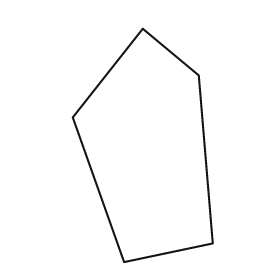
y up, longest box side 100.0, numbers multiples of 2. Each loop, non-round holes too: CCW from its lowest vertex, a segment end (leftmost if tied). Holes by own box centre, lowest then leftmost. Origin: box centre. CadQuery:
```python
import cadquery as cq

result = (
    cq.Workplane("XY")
    .moveTo(-8.0, -50.0)
    .lineTo(30.0, -42.0)
    .lineTo(24.0, 30.0)
    .lineTo(0.0, 50.0)
    .lineTo(-30.0, 12.0)
    .close()
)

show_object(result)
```